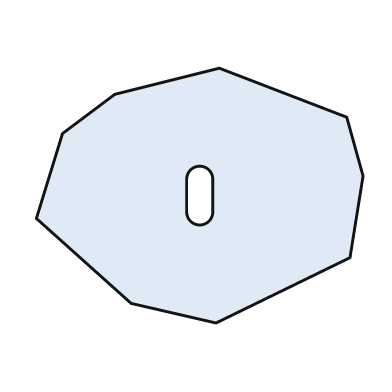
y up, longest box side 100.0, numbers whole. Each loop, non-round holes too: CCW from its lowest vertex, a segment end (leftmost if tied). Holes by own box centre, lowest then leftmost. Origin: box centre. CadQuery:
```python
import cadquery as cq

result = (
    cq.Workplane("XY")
    .moveTo(5.0, -39.0)
    .lineTo(46.0, -19.0)
    .lineTo(50.0, 6.0)
    .lineTo(45.0, 24.0)
    .lineTo(6.0, 39.0)
    .lineTo(-26.0, 31.0)
    .lineTo(-42.0, 19.0)
    .lineTo(-50.0, -7.0)
    .lineTo(-21.0, -33.0)
    .close()
    .moveTo(-4.0, -5.0)
    .threePointArc((0.0, -9.0), (4.0, -5.0))
    .lineTo(4.0, 5.0)
    .threePointArc((0.0, 9.0), (-4.0, 5.0))
    .close()
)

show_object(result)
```